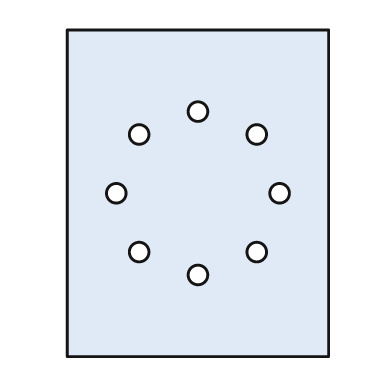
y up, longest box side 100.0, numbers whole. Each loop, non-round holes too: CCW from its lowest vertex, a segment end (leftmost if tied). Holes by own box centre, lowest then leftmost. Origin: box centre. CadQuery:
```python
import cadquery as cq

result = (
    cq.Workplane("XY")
    .moveTo(-40.0, -50.0)
    .lineTo(40.0, -50.0)
    .lineTo(40.0, 50.0)
    .lineTo(-40.0, 50.0)
    .close()
    .moveTo(0.0, -25.0)
    .circle(3.0)
    .moveTo(-18.0, -18.0)
    .circle(3.0)
    .moveTo(18.0, -18.0)
    .circle(3.0)
    .moveTo(-25.0, 0.0)
    .circle(3.0)
    .moveTo(25.0, 0.0)
    .circle(3.0)
    .moveTo(-18.0, 18.0)
    .circle(3.0)
    .moveTo(18.0, 18.0)
    .circle(3.0)
    .moveTo(0.0, 25.0)
    .circle(3.0)
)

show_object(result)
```